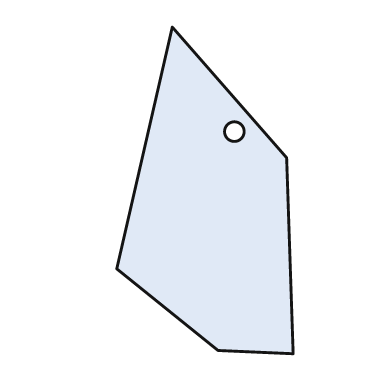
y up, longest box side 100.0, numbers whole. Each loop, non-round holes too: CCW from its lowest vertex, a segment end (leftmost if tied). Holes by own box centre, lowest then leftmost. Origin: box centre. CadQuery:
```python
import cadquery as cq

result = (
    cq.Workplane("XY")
    .moveTo(27.0, -50.0)
    .lineTo(25.0, 10.0)
    .lineTo(-10.0, 50.0)
    .lineTo(-27.0, -24.0)
    .lineTo(4.0, -49.0)
    .close()
    .moveTo(9.0, 18.0)
    .circle(3.0)
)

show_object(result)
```